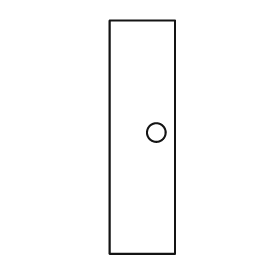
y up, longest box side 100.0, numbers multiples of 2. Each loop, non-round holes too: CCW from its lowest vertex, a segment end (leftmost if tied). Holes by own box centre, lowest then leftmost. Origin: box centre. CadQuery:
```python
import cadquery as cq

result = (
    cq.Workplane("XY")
    .moveTo(-14.0, -50.0)
    .lineTo(14.0, -50.0)
    .lineTo(14.0, 50.0)
    .lineTo(-14.0, 50.0)
    .close()
    .moveTo(6.0, 2.0)
    .circle(4.0)
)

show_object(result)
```